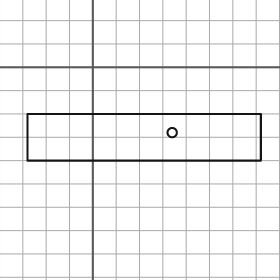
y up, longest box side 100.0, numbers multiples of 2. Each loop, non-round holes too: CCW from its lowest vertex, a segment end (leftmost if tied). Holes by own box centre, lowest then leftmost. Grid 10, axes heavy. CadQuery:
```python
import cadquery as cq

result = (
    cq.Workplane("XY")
    .moveTo(-28.0, -40.0)
    .lineTo(72.0, -40.0)
    .lineTo(72.0, -20.0)
    .lineTo(-28.0, -20.0)
    .close()
    .moveTo(34.0, -28.0)
    .circle(2.0)
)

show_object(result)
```